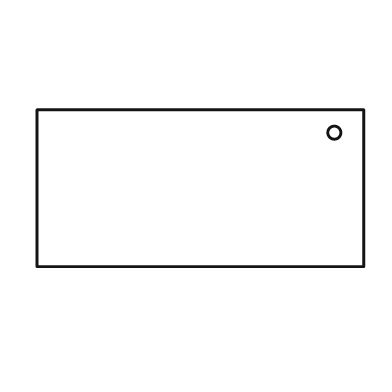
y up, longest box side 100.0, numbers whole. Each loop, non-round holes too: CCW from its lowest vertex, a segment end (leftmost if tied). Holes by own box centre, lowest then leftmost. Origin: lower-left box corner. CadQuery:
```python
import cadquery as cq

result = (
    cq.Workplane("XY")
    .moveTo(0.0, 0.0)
    .lineTo(100.0, 0.0)
    .lineTo(100.0, 48.0)
    .lineTo(0.0, 48.0)
    .close()
    .moveTo(91.0, 41.0)
    .circle(2.0)
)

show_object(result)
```